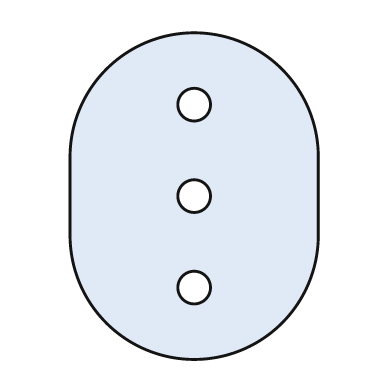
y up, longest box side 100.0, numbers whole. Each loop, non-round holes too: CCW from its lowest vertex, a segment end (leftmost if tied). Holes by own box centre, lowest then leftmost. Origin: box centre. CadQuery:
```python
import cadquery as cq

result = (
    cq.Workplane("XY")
    .moveTo(-38.0, -12.0)
    .threePointArc((0.0, -50.0), (38.0, -12.0))
    .lineTo(38.0, 12.0)
    .threePointArc((0.0, 50.0), (-38.0, 12.0))
    .close()
    .moveTo(0.0, -28.0)
    .circle(5.0)
    .moveTo(0.0, 0.0)
    .circle(5.0)
    .moveTo(0.0, 28.0)
    .circle(5.0)
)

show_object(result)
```